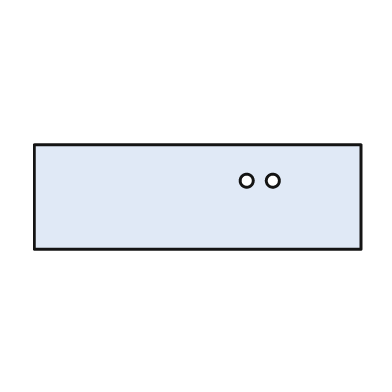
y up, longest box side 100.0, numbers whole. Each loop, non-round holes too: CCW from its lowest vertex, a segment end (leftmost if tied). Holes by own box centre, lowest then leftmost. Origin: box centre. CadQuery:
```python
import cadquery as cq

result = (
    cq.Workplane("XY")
    .moveTo(-50.0, -16.0)
    .lineTo(50.0, -16.0)
    .lineTo(50.0, 16.0)
    .lineTo(-50.0, 16.0)
    .close()
    .moveTo(15.0, 5.0)
    .circle(2.0)
    .moveTo(23.0, 5.0)
    .circle(2.0)
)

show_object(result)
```